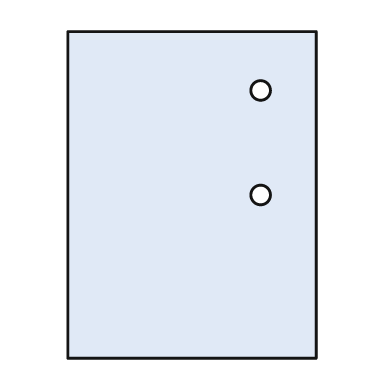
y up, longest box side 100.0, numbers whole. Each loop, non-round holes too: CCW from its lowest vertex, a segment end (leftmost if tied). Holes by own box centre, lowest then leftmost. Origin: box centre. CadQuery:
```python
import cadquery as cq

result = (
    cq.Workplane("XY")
    .moveTo(-38.0, -50.0)
    .lineTo(38.0, -50.0)
    .lineTo(38.0, 50.0)
    .lineTo(-38.0, 50.0)
    .close()
    .moveTo(21.0, 0.0)
    .circle(3.0)
    .moveTo(21.0, 32.0)
    .circle(3.0)
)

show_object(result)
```